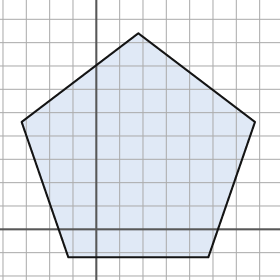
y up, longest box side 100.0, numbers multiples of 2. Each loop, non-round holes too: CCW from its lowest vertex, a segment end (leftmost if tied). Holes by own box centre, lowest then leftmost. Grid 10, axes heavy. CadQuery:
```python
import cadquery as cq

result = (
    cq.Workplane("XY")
    .moveTo(-12.0, -12.0)
    .lineTo(48.0, -12.0)
    .lineTo(68.0, 46.0)
    .lineTo(18.0, 84.0)
    .lineTo(-32.0, 46.0)
    .close()
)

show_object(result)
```